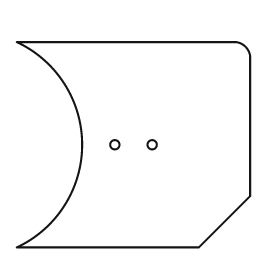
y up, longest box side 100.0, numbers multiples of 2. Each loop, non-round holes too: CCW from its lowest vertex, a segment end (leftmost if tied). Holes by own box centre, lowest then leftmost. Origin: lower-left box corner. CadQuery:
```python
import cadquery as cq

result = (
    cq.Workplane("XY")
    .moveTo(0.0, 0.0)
    .lineTo(78.0, 0.0)
    .lineTo(100.0, 22.0)
    .lineTo(100.0, 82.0)
    .threePointArc((98.0, 86.0), (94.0, 88.0))
    .lineTo(0.0, 88.0)
    .threePointArc((28.0, 44.0), (0.0, 0.0))
    .close()
    .moveTo(42.0, 44.0)
    .circle(2.0)
    .moveTo(58.0, 44.0)
    .circle(2.0)
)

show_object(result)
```